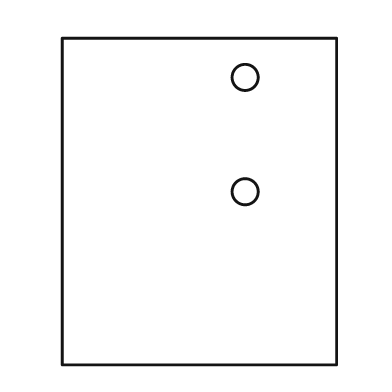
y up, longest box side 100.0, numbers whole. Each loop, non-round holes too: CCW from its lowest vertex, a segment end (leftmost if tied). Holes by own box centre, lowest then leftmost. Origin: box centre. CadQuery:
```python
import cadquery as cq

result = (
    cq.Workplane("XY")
    .moveTo(-42.0, -50.0)
    .lineTo(42.0, -50.0)
    .lineTo(42.0, 50.0)
    .lineTo(-42.0, 50.0)
    .close()
    .moveTo(14.0, 3.0)
    .circle(4.0)
    .moveTo(14.0, 38.0)
    .circle(4.0)
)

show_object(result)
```